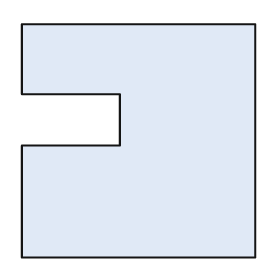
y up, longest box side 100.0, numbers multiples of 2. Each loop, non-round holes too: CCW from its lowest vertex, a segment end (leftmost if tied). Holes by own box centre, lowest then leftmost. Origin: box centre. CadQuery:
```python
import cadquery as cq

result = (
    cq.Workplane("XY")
    .moveTo(-50.0, -50.0)
    .lineTo(50.0, -50.0)
    .lineTo(50.0, 50.0)
    .lineTo(-50.0, 50.0)
    .lineTo(-50.0, 20.0)
    .lineTo(-8.0, 20.0)
    .lineTo(-8.0, -2.0)
    .lineTo(-50.0, -2.0)
    .close()
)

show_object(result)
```